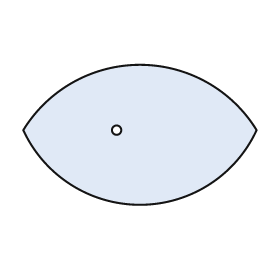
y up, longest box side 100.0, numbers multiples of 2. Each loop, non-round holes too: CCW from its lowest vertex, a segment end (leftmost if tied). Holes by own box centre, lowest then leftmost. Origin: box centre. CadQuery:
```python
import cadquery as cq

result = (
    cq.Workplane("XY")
    .moveTo(-50.0, 2.0)
    .threePointArc((0.0, -30.0), (50.0, 2.0))
    .threePointArc((0.0, 30.0), (-50.0, 2.0))
    .close()
    .moveTo(-10.0, 2.0)
    .circle(2.0)
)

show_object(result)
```